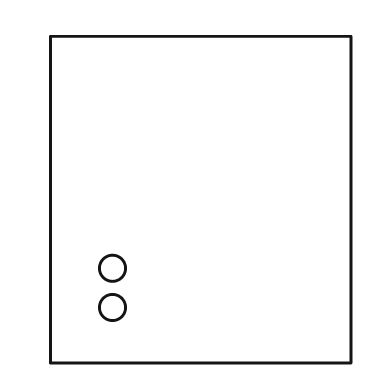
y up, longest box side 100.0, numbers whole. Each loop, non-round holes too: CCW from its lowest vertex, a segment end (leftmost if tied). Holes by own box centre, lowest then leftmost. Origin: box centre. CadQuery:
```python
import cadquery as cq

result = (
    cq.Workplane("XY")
    .moveTo(-46.0, -50.0)
    .lineTo(46.0, -50.0)
    .lineTo(46.0, 50.0)
    .lineTo(-46.0, 50.0)
    .close()
    .moveTo(-27.0, -33.0)
    .circle(4.0)
    .moveTo(-27.0, -21.0)
    .circle(4.0)
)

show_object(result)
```